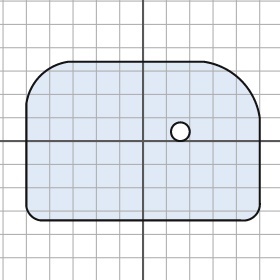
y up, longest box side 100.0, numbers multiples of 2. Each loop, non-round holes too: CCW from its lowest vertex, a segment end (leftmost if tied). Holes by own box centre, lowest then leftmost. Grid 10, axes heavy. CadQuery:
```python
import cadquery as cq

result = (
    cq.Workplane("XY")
    .moveTo(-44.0, -34.0)
    .lineTo(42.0, -34.0)
    .threePointArc((48.0, -32.0), (50.0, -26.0))
    .lineTo(50.0, 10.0)
    .threePointArc((42.0, 26.0), (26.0, 34.0))
    .lineTo(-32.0, 34.0)
    .threePointArc((-44.0, 28.0), (-50.0, 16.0))
    .lineTo(-50.0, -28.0)
    .threePointArc((-48.0, -32.0), (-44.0, -34.0))
    .close()
    .moveTo(16.0, 4.0)
    .circle(4.0)
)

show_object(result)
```